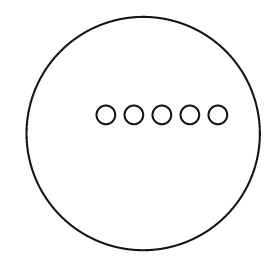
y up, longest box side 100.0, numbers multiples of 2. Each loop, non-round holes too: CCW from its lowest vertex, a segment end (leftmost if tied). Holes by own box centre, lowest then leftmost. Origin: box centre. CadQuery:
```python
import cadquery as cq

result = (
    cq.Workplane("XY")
    .moveTo(0.0, 0.0)
    .circle(50.0)
    .moveTo(-16.0, 8.0)
    .circle(4.0)
    .moveTo(-4.0, 8.0)
    .circle(4.0)
    .moveTo(8.0, 8.0)
    .circle(4.0)
    .moveTo(20.0, 8.0)
    .circle(4.0)
    .moveTo(32.0, 8.0)
    .circle(4.0)
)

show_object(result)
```